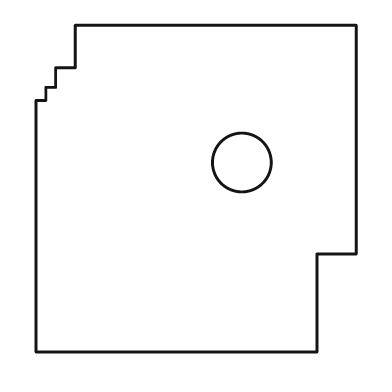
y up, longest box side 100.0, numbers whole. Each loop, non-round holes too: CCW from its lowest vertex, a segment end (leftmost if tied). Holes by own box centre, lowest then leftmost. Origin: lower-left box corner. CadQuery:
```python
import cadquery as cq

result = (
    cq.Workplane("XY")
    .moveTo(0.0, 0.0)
    .lineTo(86.0, 0.0)
    .lineTo(86.0, 30.0)
    .lineTo(98.0, 30.0)
    .lineTo(98.0, 100.0)
    .lineTo(12.0, 100.0)
    .lineTo(12.0, 87.0)
    .lineTo(6.0, 87.0)
    .lineTo(6.0, 81.0)
    .lineTo(3.0, 81.0)
    .lineTo(3.0, 77.0)
    .lineTo(0.0, 77.0)
    .close()
    .moveTo(63.0, 58.0)
    .circle(9.0)
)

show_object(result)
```